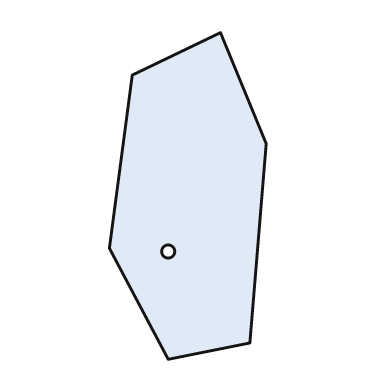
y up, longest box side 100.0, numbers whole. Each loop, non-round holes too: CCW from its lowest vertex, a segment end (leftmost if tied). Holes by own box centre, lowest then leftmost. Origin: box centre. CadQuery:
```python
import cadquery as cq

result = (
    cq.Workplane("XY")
    .moveTo(-6.0, -50.0)
    .lineTo(19.0, -45.0)
    .lineTo(24.0, 16.0)
    .lineTo(10.0, 50.0)
    .lineTo(-17.0, 37.0)
    .lineTo(-24.0, -16.0)
    .close()
    .moveTo(-6.0, -17.0)
    .circle(2.0)
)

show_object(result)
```